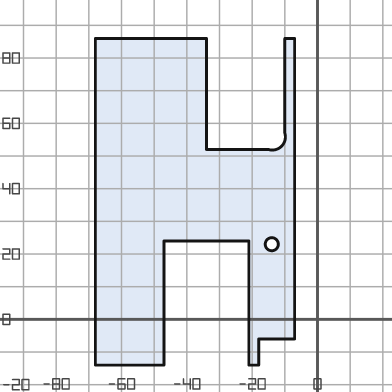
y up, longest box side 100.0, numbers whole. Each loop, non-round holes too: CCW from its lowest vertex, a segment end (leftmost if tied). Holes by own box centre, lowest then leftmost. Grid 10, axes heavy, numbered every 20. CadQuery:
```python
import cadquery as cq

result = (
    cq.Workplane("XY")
    .moveTo(-68.0, -14.0)
    .lineTo(-47.0, -14.0)
    .lineTo(-47.0, 24.0)
    .lineTo(-21.0, 24.0)
    .lineTo(-21.0, -14.0)
    .lineTo(-18.0, -14.0)
    .lineTo(-18.0, -6.0)
    .lineTo(-7.0, -6.0)
    .lineTo(-7.0, 86.0)
    .lineTo(-10.0, 86.0)
    .lineTo(-10.0, 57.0)
    .threePointArc((-11.0, 53.0), (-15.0, 52.0))
    .lineTo(-34.0, 52.0)
    .lineTo(-34.0, 86.0)
    .lineTo(-68.0, 86.0)
    .close()
    .moveTo(-14.0, 23.0)
    .circle(2.0)
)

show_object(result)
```